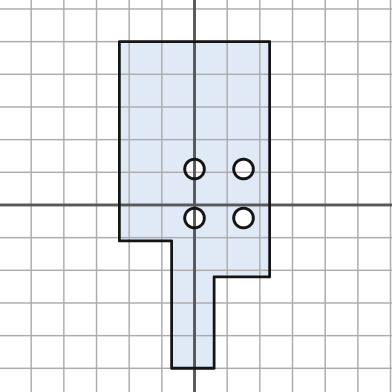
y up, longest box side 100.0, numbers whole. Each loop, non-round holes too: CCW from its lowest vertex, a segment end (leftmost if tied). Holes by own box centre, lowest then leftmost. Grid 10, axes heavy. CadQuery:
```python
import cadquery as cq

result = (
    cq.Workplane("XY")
    .moveTo(-7.0, -50.0)
    .lineTo(6.0, -50.0)
    .lineTo(6.0, -22.0)
    .lineTo(23.0, -22.0)
    .lineTo(23.0, 50.0)
    .lineTo(-23.0, 50.0)
    .lineTo(-23.0, -11.0)
    .lineTo(-7.0, -11.0)
    .close()
    .moveTo(0.0, -4.0)
    .circle(3.0)
    .moveTo(15.0, -4.0)
    .circle(3.0)
    .moveTo(0.0, 11.0)
    .circle(3.0)
    .moveTo(15.0, 11.0)
    .circle(3.0)
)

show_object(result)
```